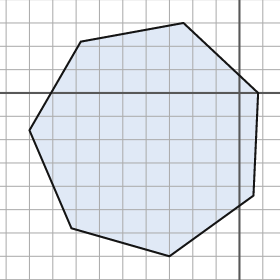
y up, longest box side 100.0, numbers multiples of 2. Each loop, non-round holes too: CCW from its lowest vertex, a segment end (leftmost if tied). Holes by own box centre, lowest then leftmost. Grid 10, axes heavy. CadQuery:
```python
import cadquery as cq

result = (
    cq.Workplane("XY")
    .moveTo(-30.0, -70.0)
    .lineTo(6.0, -44.0)
    .lineTo(8.0, 0.0)
    .lineTo(-24.0, 30.0)
    .lineTo(-68.0, 22.0)
    .lineTo(-90.0, -16.0)
    .lineTo(-72.0, -58.0)
    .close()
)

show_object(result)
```